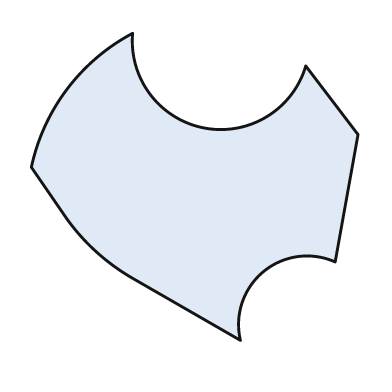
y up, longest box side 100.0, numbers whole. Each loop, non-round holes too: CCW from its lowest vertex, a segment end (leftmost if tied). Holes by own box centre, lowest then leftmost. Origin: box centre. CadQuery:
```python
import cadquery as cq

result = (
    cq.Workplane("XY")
    .moveTo(14.0, -47.0)
    .threePointArc((21.0, -26.0), (43.0, -23.0))
    .lineTo(50.0, 16.0)
    .lineTo(34.0, 37.0)
    .threePointArc((3.0, 18.0), (-19.0, 47.0))
    .threePointArc((-39.0, 30.0), (-50.0, 6.0))
    .lineTo(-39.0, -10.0)
    .threePointArc((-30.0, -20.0), (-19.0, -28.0))
    .close()
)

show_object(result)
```